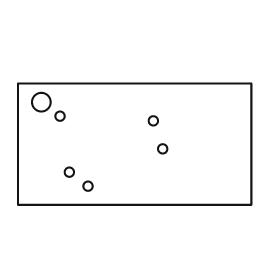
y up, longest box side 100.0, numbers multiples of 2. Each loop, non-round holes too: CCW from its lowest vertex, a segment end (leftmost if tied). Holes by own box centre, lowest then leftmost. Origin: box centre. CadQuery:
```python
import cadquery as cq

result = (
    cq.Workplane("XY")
    .moveTo(-50.0, -26.0)
    .lineTo(50.0, -26.0)
    .lineTo(50.0, 26.0)
    .lineTo(-50.0, 26.0)
    .close()
    .moveTo(-20.0, -18.0)
    .circle(2.0)
    .moveTo(-28.0, -12.0)
    .circle(2.0)
    .moveTo(12.0, -2.0)
    .circle(2.0)
    .moveTo(8.0, 10.0)
    .circle(2.0)
    .moveTo(-32.0, 12.0)
    .circle(2.0)
    .moveTo(-40.0, 18.0)
    .circle(4.0)
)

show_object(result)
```